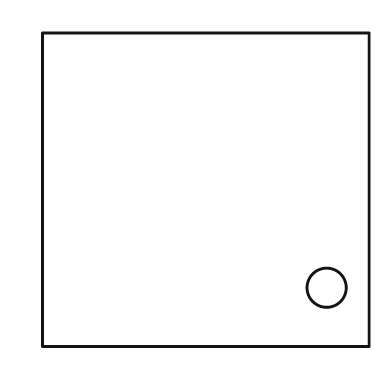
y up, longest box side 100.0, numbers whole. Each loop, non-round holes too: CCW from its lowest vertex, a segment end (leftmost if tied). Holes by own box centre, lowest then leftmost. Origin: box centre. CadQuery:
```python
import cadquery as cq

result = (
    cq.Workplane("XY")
    .moveTo(-50.0, -48.0)
    .lineTo(50.0, -48.0)
    .lineTo(50.0, 48.0)
    .lineTo(-50.0, 48.0)
    .close()
    .moveTo(37.0, -30.0)
    .circle(6.0)
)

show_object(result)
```